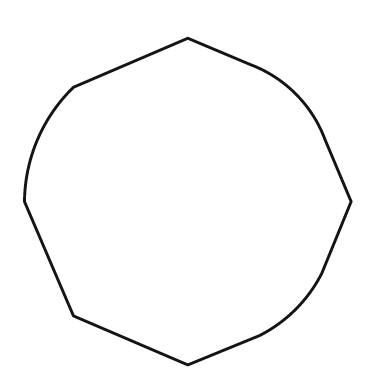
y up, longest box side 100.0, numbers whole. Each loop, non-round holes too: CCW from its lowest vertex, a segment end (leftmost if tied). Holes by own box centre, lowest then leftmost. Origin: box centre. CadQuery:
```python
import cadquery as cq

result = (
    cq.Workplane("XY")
    .moveTo(0.0, -50.0)
    .lineTo(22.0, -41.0)
    .threePointArc((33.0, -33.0), (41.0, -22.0))
    .lineTo(50.0, 0.0)
    .lineTo(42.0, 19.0)
    .threePointArc((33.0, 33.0), (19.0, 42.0))
    .lineTo(0.0, 50.0)
    .lineTo(-35.0, 35.0)
    .threePointArc((-46.0, 19.0), (-50.0, 0.0))
    .lineTo(-35.0, -35.0)
    .close()
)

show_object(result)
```